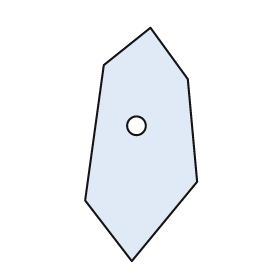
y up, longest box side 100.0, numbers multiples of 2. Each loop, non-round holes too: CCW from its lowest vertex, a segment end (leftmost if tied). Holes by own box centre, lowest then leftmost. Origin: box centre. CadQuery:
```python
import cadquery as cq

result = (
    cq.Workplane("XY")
    .moveTo(-4.0, -50.0)
    .lineTo(24.0, -16.0)
    .lineTo(20.0, 28.0)
    .lineTo(4.0, 50.0)
    .lineTo(-16.0, 34.0)
    .lineTo(-24.0, -24.0)
    .close()
    .moveTo(-2.0, 8.0)
    .circle(4.0)
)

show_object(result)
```